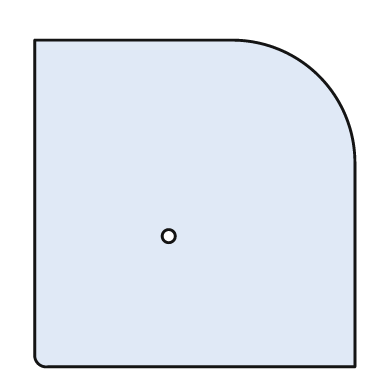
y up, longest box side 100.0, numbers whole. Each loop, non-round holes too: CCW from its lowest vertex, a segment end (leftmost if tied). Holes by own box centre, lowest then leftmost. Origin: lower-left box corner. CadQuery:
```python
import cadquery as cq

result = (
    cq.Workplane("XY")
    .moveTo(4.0, 0.0)
    .lineTo(98.0, 0.0)
    .lineTo(98.0, 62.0)
    .threePointArc((87.0, 89.0), (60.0, 100.0))
    .lineTo(0.0, 100.0)
    .lineTo(0.0, 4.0)
    .threePointArc((1.0, 1.0), (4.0, 0.0))
    .close()
    .moveTo(41.0, 40.0)
    .circle(2.0)
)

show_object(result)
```